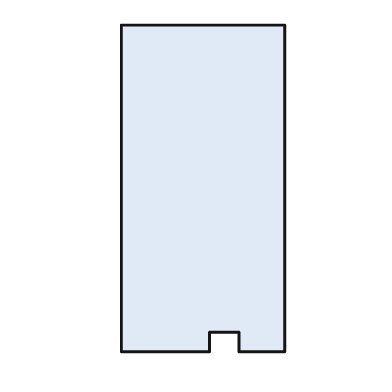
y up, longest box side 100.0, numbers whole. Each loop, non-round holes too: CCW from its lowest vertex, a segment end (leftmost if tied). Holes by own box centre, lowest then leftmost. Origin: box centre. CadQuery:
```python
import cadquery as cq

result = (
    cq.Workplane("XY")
    .moveTo(-25.0, -50.0)
    .lineTo(2.0, -50.0)
    .lineTo(2.0, -44.0)
    .lineTo(11.0, -44.0)
    .lineTo(11.0, -50.0)
    .lineTo(25.0, -50.0)
    .lineTo(25.0, 50.0)
    .lineTo(-25.0, 50.0)
    .close()
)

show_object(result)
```